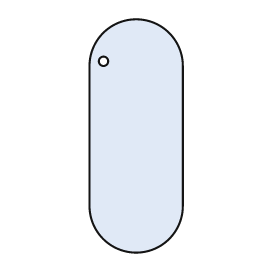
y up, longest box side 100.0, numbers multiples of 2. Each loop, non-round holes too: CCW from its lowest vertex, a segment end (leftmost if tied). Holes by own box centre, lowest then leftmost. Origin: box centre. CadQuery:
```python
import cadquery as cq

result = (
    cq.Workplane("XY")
    .moveTo(-20.0, -30.0)
    .threePointArc((0.0, -50.0), (20.0, -30.0))
    .lineTo(20.0, 30.0)
    .threePointArc((0.0, 50.0), (-20.0, 30.0))
    .close()
    .moveTo(-14.0, 32.0)
    .circle(2.0)
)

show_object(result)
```